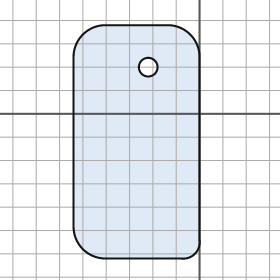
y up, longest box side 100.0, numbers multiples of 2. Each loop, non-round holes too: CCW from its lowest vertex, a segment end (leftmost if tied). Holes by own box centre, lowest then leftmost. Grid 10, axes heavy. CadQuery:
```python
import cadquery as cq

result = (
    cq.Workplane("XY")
    .moveTo(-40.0, -62.0)
    .lineTo(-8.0, -62.0)
    .threePointArc((-2.0, -60.0), (0.0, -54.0))
    .lineTo(0.0, 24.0)
    .threePointArc((-4.0, 34.0), (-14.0, 38.0))
    .lineTo(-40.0, 38.0)
    .threePointArc((-50.0, 34.0), (-54.0, 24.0))
    .lineTo(-54.0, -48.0)
    .threePointArc((-50.0, -58.0), (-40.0, -62.0))
    .close()
    .moveTo(-22.0, 20.0)
    .circle(4.0)
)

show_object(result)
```